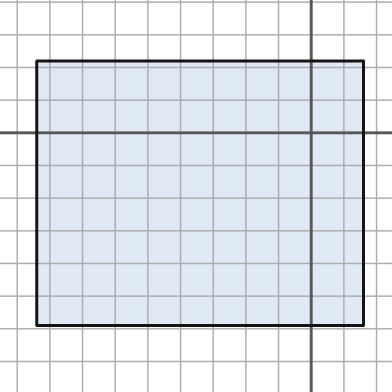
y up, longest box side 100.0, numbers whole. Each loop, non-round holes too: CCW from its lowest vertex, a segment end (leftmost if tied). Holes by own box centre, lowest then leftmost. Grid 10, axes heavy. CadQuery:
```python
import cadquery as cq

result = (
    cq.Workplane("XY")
    .moveTo(-84.0, -59.0)
    .lineTo(16.0, -59.0)
    .lineTo(16.0, 22.0)
    .lineTo(-84.0, 22.0)
    .close()
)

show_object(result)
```